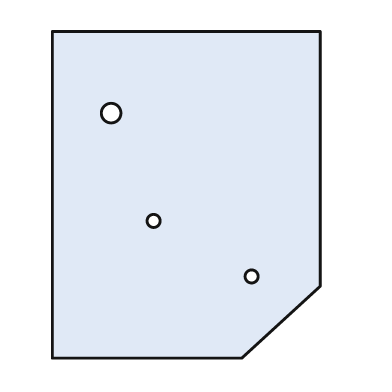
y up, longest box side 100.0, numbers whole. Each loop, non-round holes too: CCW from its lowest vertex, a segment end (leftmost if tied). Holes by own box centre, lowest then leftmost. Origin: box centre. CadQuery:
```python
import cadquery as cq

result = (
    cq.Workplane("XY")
    .moveTo(-41.0, -50.0)
    .lineTo(17.0, -50.0)
    .lineTo(41.0, -28.0)
    .lineTo(41.0, 50.0)
    .lineTo(-41.0, 50.0)
    .close()
    .moveTo(20.0, -25.0)
    .circle(2.0)
    .moveTo(-10.0, -8.0)
    .circle(2.0)
    .moveTo(-23.0, 25.0)
    .circle(3.0)
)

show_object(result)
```